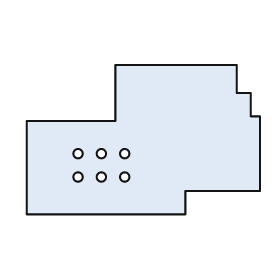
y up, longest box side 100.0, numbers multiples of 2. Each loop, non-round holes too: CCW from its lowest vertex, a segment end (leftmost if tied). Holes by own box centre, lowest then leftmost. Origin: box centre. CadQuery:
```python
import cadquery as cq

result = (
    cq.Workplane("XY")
    .moveTo(-50.0, -32.0)
    .lineTo(18.0, -32.0)
    .lineTo(18.0, -22.0)
    .lineTo(50.0, -22.0)
    .lineTo(50.0, 10.0)
    .lineTo(46.0, 10.0)
    .lineTo(46.0, 20.0)
    .lineTo(40.0, 20.0)
    .lineTo(40.0, 32.0)
    .lineTo(-12.0, 32.0)
    .lineTo(-12.0, 8.0)
    .lineTo(-50.0, 8.0)
    .close()
    .moveTo(-28.0, -16.0)
    .circle(2.0)
    .moveTo(-18.0, -16.0)
    .circle(2.0)
    .moveTo(-8.0, -16.0)
    .circle(2.0)
    .moveTo(-28.0, -6.0)
    .circle(2.0)
    .moveTo(-18.0, -6.0)
    .circle(2.0)
    .moveTo(-8.0, -6.0)
    .circle(2.0)
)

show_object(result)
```